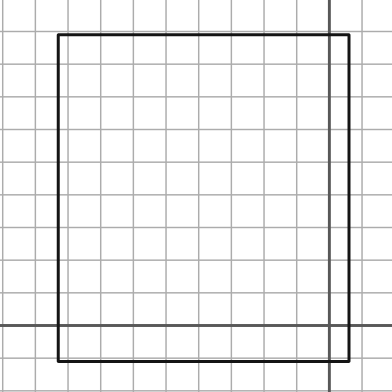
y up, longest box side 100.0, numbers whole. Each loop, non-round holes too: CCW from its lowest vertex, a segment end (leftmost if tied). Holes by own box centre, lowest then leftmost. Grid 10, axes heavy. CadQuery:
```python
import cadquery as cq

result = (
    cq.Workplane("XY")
    .moveTo(-83.0, -11.0)
    .lineTo(6.0, -11.0)
    .lineTo(6.0, 89.0)
    .lineTo(-83.0, 89.0)
    .close()
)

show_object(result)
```